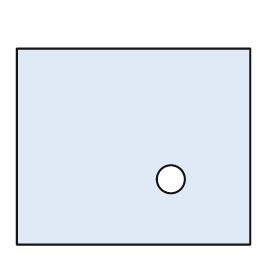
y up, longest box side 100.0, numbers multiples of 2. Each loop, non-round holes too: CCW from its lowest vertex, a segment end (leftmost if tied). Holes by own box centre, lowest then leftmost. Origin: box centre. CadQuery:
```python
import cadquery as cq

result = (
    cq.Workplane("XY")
    .moveTo(-50.0, -42.0)
    .lineTo(50.0, -42.0)
    .lineTo(50.0, 42.0)
    .lineTo(-50.0, 42.0)
    .close()
    .moveTo(16.0, -14.0)
    .circle(6.0)
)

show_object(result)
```